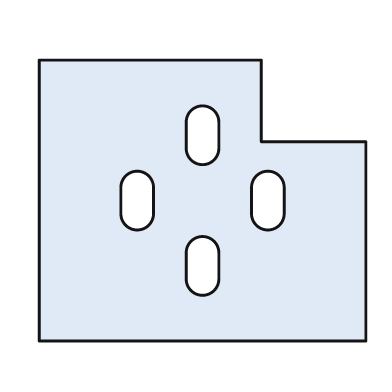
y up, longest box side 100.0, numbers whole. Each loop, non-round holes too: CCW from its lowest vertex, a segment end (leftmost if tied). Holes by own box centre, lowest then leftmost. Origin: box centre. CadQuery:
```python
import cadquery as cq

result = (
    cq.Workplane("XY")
    .moveTo(-50.0, -43.0)
    .lineTo(50.0, -43.0)
    .lineTo(50.0, 18.0)
    .lineTo(18.0, 18.0)
    .lineTo(18.0, 43.0)
    .lineTo(-50.0, 43.0)
    .close()
    .moveTo(-5.0, -24.0)
    .threePointArc((0.0, -29.0), (5.0, -24.0))
    .lineTo(5.0, -16.0)
    .threePointArc((0.0, -11.0), (-5.0, -16.0))
    .close()
    .moveTo(-25.0, -4.0)
    .threePointArc((-20.0, -9.0), (-15.0, -4.0))
    .lineTo(-15.0, 4.0)
    .threePointArc((-20.0, 9.0), (-25.0, 4.0))
    .close()
    .moveTo(15.0, -4.0)
    .threePointArc((20.0, -9.0), (25.0, -4.0))
    .lineTo(25.0, 4.0)
    .threePointArc((20.0, 9.0), (15.0, 4.0))
    .close()
    .moveTo(-5.0, 16.0)
    .threePointArc((0.0, 11.0), (5.0, 16.0))
    .lineTo(5.0, 24.0)
    .threePointArc((0.0, 29.0), (-5.0, 24.0))
    .close()
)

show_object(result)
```